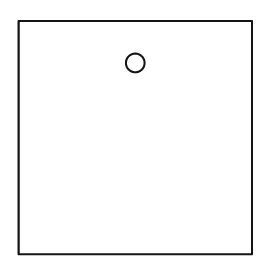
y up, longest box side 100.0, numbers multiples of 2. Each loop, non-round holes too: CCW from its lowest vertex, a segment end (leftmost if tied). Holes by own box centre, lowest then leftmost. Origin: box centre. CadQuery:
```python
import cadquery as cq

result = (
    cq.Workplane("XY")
    .moveTo(-50.0, -50.0)
    .lineTo(50.0, -50.0)
    .lineTo(50.0, 50.0)
    .lineTo(-50.0, 50.0)
    .close()
    .moveTo(0.0, 32.0)
    .circle(4.0)
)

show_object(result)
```